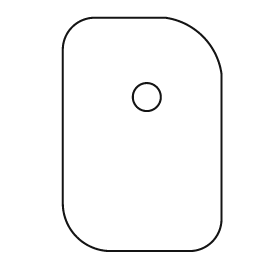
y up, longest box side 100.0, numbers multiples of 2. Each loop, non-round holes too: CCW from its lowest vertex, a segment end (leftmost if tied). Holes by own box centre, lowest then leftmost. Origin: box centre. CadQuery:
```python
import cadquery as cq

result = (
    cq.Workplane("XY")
    .moveTo(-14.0, -50.0)
    .lineTo(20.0, -50.0)
    .threePointArc((30.0, -46.0), (34.0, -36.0))
    .lineTo(34.0, 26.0)
    .threePointArc((26.0, 42.0), (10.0, 50.0))
    .lineTo(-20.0, 50.0)
    .threePointArc((-30.0, 46.0), (-34.0, 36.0))
    .lineTo(-34.0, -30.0)
    .threePointArc((-28.0, -44.0), (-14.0, -50.0))
    .close()
    .moveTo(2.0, 16.0)
    .circle(6.0)
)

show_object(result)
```